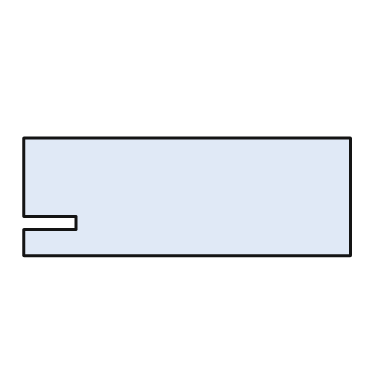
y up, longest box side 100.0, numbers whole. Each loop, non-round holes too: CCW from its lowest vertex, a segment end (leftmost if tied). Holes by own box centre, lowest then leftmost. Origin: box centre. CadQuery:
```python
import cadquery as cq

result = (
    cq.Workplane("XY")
    .moveTo(-50.0, -18.0)
    .lineTo(50.0, -18.0)
    .lineTo(50.0, 18.0)
    .lineTo(-50.0, 18.0)
    .lineTo(-50.0, -6.0)
    .lineTo(-34.0, -6.0)
    .lineTo(-34.0, -10.0)
    .lineTo(-50.0, -10.0)
    .close()
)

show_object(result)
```